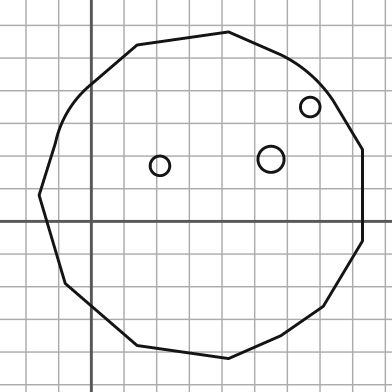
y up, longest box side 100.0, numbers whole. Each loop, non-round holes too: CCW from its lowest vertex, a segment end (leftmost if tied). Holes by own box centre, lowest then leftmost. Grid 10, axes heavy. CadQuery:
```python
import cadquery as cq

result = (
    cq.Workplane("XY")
    .moveTo(42.0, -42.0)
    .lineTo(58.0, -35.0)
    .lineTo(71.0, -26.0)
    .lineTo(83.0, -6.0)
    .lineTo(83.0, 22.0)
    .lineTo(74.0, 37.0)
    .threePointArc((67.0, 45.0), (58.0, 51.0))
    .lineTo(42.0, 58.0)
    .lineTo(14.0, 54.0)
    .lineTo(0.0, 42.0)
    .threePointArc((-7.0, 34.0), (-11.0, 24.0))
    .lineTo(-16.0, 8.0)
    .lineTo(-8.0, -19.0)
    .lineTo(14.0, -38.0)
    .close()
    .moveTo(21.0, 17.0)
    .circle(3.0)
    .moveTo(55.0, 19.0)
    .circle(4.0)
    .moveTo(67.0, 35.0)
    .circle(3.0)
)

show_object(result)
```